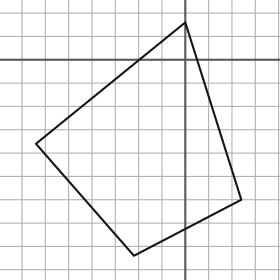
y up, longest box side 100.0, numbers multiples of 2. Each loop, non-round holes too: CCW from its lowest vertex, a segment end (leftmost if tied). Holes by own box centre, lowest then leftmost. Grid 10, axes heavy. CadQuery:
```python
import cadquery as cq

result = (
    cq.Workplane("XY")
    .moveTo(-22.0, -84.0)
    .lineTo(24.0, -60.0)
    .lineTo(0.0, 16.0)
    .lineTo(-64.0, -36.0)
    .close()
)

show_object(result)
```